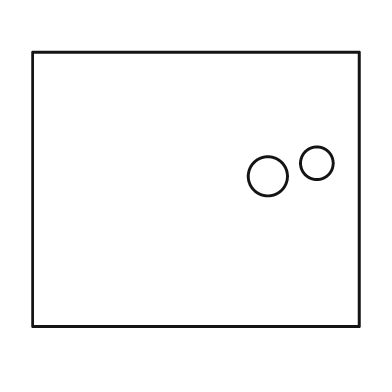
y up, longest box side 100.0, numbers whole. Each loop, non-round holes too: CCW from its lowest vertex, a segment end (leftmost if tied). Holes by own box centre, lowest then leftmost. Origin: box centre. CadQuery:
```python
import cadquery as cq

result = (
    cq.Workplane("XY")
    .moveTo(-50.0, -42.0)
    .lineTo(50.0, -42.0)
    .lineTo(50.0, 42.0)
    .lineTo(-50.0, 42.0)
    .close()
    .moveTo(22.0, 4.0)
    .circle(6.0)
    .moveTo(37.0, 8.0)
    .circle(5.0)
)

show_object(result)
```